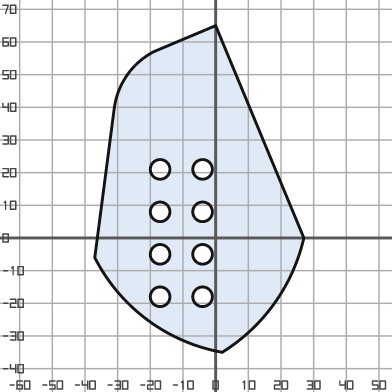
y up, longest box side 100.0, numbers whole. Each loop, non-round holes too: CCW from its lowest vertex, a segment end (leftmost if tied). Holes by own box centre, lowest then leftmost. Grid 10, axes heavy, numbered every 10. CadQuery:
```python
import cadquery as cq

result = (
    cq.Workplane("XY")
    .moveTo(2.0, -35.0)
    .threePointArc((18.0, -20.0), (27.0, 0.0))
    .lineTo(0.0, 65.0)
    .lineTo(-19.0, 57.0)
    .threePointArc((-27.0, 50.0), (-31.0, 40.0))
    .lineTo(-37.0, -6.0)
    .threePointArc((-21.0, -25.0), (2.0, -35.0))
    .close()
    .moveTo(-17.0, -18.0)
    .circle(3.0)
    .moveTo(-4.0, -18.0)
    .circle(3.0)
    .moveTo(-17.0, -5.0)
    .circle(3.0)
    .moveTo(-4.0, -5.0)
    .circle(3.0)
    .moveTo(-17.0, 8.0)
    .circle(3.0)
    .moveTo(-4.0, 8.0)
    .circle(3.0)
    .moveTo(-17.0, 21.0)
    .circle(3.0)
    .moveTo(-4.0, 21.0)
    .circle(3.0)
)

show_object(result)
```